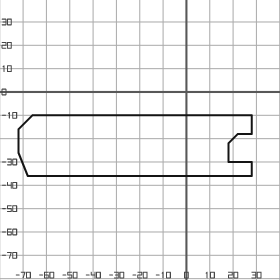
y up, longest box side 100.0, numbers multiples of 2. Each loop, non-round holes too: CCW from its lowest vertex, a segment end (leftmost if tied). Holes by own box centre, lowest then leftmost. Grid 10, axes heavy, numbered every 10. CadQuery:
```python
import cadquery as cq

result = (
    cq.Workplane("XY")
    .moveTo(-68.0, -36.0)
    .lineTo(28.0, -36.0)
    .lineTo(28.0, -30.0)
    .lineTo(18.0, -30.0)
    .lineTo(18.0, -22.0)
    .lineTo(22.0, -18.0)
    .lineTo(28.0, -18.0)
    .lineTo(28.0, -10.0)
    .lineTo(-66.0, -10.0)
    .lineTo(-72.0, -16.0)
    .lineTo(-72.0, -26.0)
    .close()
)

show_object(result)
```